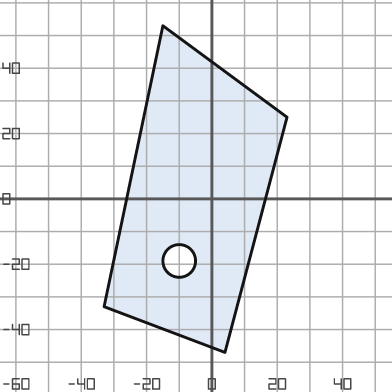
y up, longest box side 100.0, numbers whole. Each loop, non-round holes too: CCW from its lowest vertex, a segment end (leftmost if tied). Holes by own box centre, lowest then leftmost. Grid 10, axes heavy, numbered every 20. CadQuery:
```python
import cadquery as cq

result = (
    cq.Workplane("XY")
    .moveTo(4.0, -47.0)
    .lineTo(23.0, 25.0)
    .lineTo(-15.0, 53.0)
    .lineTo(-33.0, -33.0)
    .close()
    .moveTo(-10.0, -19.0)
    .circle(5.0)
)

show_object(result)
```